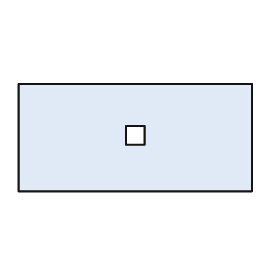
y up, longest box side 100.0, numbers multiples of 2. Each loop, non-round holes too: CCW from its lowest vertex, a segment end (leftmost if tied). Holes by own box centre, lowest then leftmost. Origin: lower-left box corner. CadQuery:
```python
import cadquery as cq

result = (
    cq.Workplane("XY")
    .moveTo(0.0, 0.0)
    .lineTo(100.0, 0.0)
    .lineTo(100.0, 46.0)
    .lineTo(0.0, 46.0)
    .close()
    .moveTo(46.0, 20.0)
    .lineTo(54.0, 20.0)
    .lineTo(54.0, 28.0)
    .lineTo(46.0, 28.0)
    .close()
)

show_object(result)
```